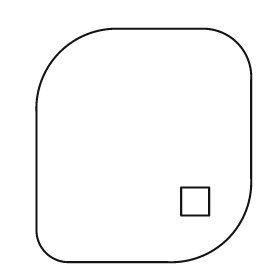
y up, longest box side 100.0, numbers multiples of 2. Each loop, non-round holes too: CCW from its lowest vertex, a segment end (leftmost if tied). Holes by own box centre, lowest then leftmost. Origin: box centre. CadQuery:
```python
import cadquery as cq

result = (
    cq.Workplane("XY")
    .moveTo(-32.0, -50.0)
    .lineTo(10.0, -50.0)
    .threePointArc((36.0, -40.0), (46.0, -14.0))
    .lineTo(46.0, 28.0)
    .threePointArc((40.0, 44.0), (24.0, 50.0))
    .lineTo(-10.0, 50.0)
    .threePointArc((-36.0, 40.0), (-46.0, 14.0))
    .lineTo(-46.0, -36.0)
    .threePointArc((-42.0, -46.0), (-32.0, -50.0))
    .close()
    .moveTo(16.0, -30.0)
    .lineTo(28.0, -30.0)
    .lineTo(28.0, -18.0)
    .lineTo(16.0, -18.0)
    .close()
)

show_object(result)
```